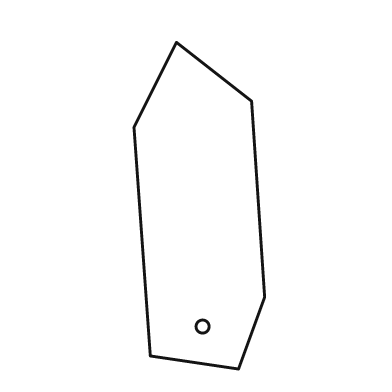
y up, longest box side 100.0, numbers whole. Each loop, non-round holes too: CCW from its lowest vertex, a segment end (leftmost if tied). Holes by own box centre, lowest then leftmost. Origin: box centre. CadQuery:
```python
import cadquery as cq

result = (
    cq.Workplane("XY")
    .moveTo(12.0, -50.0)
    .lineTo(20.0, -28.0)
    .lineTo(16.0, 32.0)
    .lineTo(-7.0, 50.0)
    .lineTo(-20.0, 24.0)
    .lineTo(-15.0, -46.0)
    .close()
    .moveTo(1.0, -37.0)
    .circle(2.0)
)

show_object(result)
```